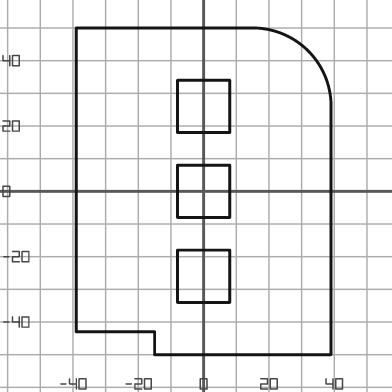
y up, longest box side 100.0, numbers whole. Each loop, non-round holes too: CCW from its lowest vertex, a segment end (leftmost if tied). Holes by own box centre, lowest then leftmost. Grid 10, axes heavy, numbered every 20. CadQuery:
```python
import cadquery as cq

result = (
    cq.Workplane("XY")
    .moveTo(-15.0, -50.0)
    .lineTo(39.0, -50.0)
    .lineTo(39.0, 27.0)
    .threePointArc((32.0, 43.0), (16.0, 50.0))
    .lineTo(-39.0, 50.0)
    .lineTo(-39.0, -43.0)
    .lineTo(-15.0, -43.0)
    .close()
    .moveTo(-8.0, -34.0)
    .lineTo(8.0, -34.0)
    .lineTo(8.0, -18.0)
    .lineTo(-8.0, -18.0)
    .close()
    .moveTo(-8.0, -8.0)
    .lineTo(8.0, -8.0)
    .lineTo(8.0, 8.0)
    .lineTo(-8.0, 8.0)
    .close()
    .moveTo(-8.0, 18.0)
    .lineTo(8.0, 18.0)
    .lineTo(8.0, 34.0)
    .lineTo(-8.0, 34.0)
    .close()
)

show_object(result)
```